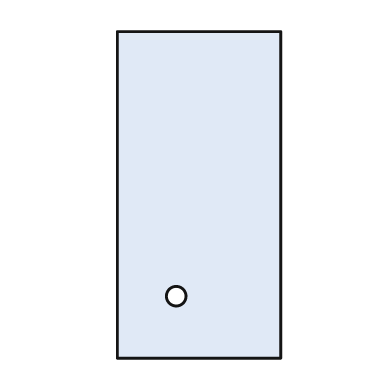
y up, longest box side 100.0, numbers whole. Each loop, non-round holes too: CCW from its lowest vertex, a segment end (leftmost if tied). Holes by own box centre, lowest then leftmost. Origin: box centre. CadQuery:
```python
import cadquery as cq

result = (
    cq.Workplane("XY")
    .moveTo(-25.0, -50.0)
    .lineTo(25.0, -50.0)
    .lineTo(25.0, 50.0)
    .lineTo(-25.0, 50.0)
    .close()
    .moveTo(-7.0, -31.0)
    .circle(3.0)
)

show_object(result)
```